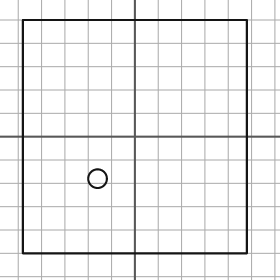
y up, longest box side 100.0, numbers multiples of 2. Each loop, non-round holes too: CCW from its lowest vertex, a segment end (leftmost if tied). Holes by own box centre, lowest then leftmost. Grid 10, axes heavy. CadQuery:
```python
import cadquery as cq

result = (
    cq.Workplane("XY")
    .moveTo(-48.0, -50.0)
    .lineTo(48.0, -50.0)
    .lineTo(48.0, 50.0)
    .lineTo(-48.0, 50.0)
    .close()
    .moveTo(-16.0, -18.0)
    .circle(4.0)
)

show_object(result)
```